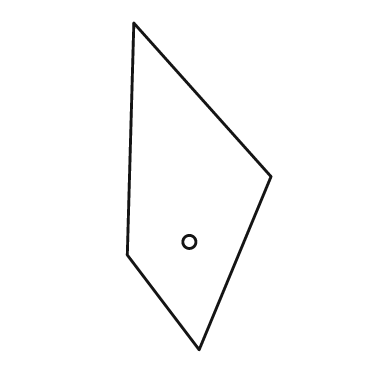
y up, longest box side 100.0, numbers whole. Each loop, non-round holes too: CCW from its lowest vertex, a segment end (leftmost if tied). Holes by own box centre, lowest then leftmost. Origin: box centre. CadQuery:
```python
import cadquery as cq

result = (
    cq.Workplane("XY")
    .moveTo(0.0, -50.0)
    .lineTo(22.0, 3.0)
    .lineTo(-20.0, 50.0)
    .lineTo(-22.0, -21.0)
    .close()
    .moveTo(-3.0, -17.0)
    .circle(2.0)
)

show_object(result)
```